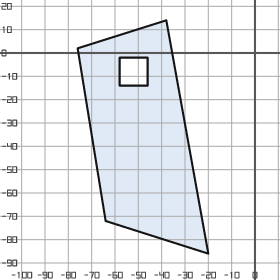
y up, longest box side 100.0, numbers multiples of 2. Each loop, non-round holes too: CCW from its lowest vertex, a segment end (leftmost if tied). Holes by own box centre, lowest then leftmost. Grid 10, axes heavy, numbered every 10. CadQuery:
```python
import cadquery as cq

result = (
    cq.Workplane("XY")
    .moveTo(-20.0, -86.0)
    .lineTo(-38.0, 14.0)
    .lineTo(-76.0, 2.0)
    .lineTo(-64.0, -72.0)
    .close()
    .moveTo(-58.0, -14.0)
    .lineTo(-46.0, -14.0)
    .lineTo(-46.0, -2.0)
    .lineTo(-58.0, -2.0)
    .close()
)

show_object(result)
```